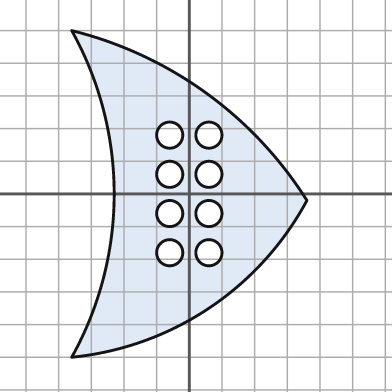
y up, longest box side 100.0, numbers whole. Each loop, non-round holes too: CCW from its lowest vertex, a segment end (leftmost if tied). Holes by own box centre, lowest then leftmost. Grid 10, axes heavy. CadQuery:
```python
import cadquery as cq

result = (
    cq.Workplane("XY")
    .moveTo(-36.0, -50.0)
    .threePointArc((6.0, -35.0), (36.0, -2.0))
    .threePointArc((5.0, 31.0), (-36.0, 50.0))
    .threePointArc((-23.0, 0.0), (-36.0, -50.0))
    .close()
    .moveTo(-6.0, -18.0)
    .circle(4.0)
    .moveTo(6.0, -18.0)
    .circle(4.0)
    .moveTo(-6.0, -6.0)
    .circle(4.0)
    .moveTo(6.0, -6.0)
    .circle(4.0)
    .moveTo(-6.0, 6.0)
    .circle(4.0)
    .moveTo(6.0, 6.0)
    .circle(4.0)
    .moveTo(-6.0, 18.0)
    .circle(4.0)
    .moveTo(6.0, 18.0)
    .circle(4.0)
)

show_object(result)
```